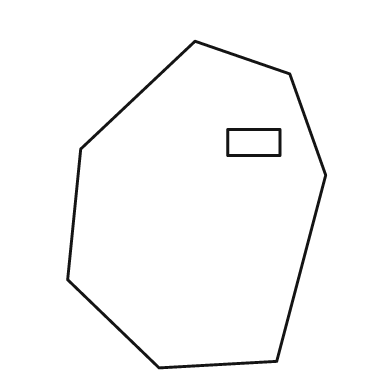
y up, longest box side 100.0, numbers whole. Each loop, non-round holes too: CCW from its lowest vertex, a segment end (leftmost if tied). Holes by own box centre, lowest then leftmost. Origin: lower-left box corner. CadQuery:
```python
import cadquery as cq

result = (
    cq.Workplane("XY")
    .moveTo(28.0, 0.0)
    .lineTo(64.0, 2.0)
    .lineTo(79.0, 59.0)
    .lineTo(68.0, 90.0)
    .lineTo(39.0, 100.0)
    .lineTo(4.0, 67.0)
    .lineTo(0.0, 27.0)
    .close()
    .moveTo(49.0, 65.0)
    .lineTo(65.0, 65.0)
    .lineTo(65.0, 73.0)
    .lineTo(49.0, 73.0)
    .close()
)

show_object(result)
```